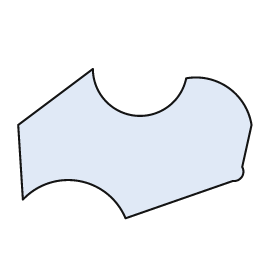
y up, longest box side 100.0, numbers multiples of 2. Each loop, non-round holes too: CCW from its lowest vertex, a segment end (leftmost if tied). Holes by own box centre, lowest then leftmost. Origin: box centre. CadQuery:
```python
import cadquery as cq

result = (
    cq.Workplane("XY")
    .moveTo(-4.0, -32.0)
    .lineTo(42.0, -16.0)
    .threePointArc((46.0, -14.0), (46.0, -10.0))
    .lineTo(50.0, 8.0)
    .threePointArc((40.0, 24.0), (22.0, 28.0))
    .threePointArc((0.0, 12.0), (-18.0, 32.0))
    .lineTo(-50.0, 8.0)
    .lineTo(-48.0, -24.0)
    .threePointArc((-24.0, -16.0), (-4.0, -32.0))
    .close()
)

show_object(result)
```